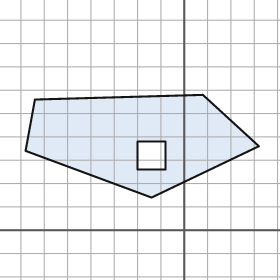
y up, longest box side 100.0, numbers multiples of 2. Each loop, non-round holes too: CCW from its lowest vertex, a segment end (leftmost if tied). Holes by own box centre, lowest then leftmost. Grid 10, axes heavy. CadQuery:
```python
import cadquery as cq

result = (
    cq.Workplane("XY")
    .moveTo(-14.0, 14.0)
    .lineTo(32.0, 36.0)
    .lineTo(8.0, 58.0)
    .lineTo(-64.0, 56.0)
    .lineTo(-68.0, 34.0)
    .close()
    .moveTo(-20.0, 26.0)
    .lineTo(-8.0, 26.0)
    .lineTo(-8.0, 38.0)
    .lineTo(-20.0, 38.0)
    .close()
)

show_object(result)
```